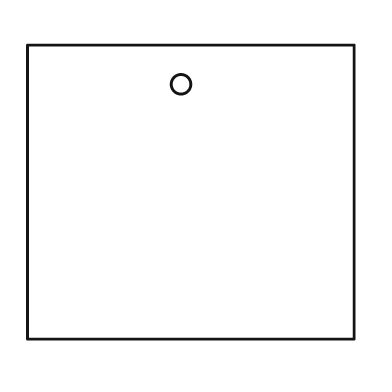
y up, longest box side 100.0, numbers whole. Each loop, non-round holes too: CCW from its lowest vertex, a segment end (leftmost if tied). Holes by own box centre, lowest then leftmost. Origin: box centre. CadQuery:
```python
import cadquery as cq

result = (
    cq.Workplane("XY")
    .moveTo(-50.0, -45.0)
    .lineTo(50.0, -45.0)
    .lineTo(50.0, 45.0)
    .lineTo(-50.0, 45.0)
    .close()
    .moveTo(-3.0, 33.0)
    .circle(3.0)
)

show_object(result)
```